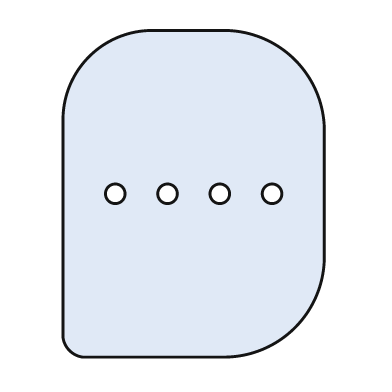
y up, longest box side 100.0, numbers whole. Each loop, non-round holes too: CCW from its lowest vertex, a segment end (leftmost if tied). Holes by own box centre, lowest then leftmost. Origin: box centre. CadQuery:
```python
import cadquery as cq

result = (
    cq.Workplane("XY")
    .moveTo(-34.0, -50.0)
    .lineTo(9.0, -50.0)
    .threePointArc((31.0, -41.0), (40.0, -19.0))
    .lineTo(40.0, 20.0)
    .threePointArc((31.0, 41.0), (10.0, 50.0))
    .lineTo(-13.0, 50.0)
    .threePointArc((-32.0, 42.0), (-40.0, 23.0))
    .lineTo(-40.0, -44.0)
    .threePointArc((-38.0, -48.0), (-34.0, -50.0))
    .close()
    .moveTo(-24.0, 0.0)
    .circle(3.0)
    .moveTo(-8.0, 0.0)
    .circle(3.0)
    .moveTo(8.0, 0.0)
    .circle(3.0)
    .moveTo(24.0, 0.0)
    .circle(3.0)
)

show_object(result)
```